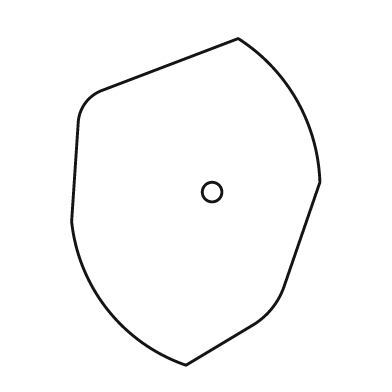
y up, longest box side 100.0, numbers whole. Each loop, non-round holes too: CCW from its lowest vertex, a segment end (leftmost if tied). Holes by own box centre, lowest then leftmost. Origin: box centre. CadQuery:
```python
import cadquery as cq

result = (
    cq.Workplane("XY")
    .moveTo(-3.0, -50.0)
    .lineTo(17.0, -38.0)
    .threePointArc((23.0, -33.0), (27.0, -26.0))
    .lineTo(38.0, 6.0)
    .threePointArc((31.0, 31.0), (13.0, 50.0))
    .lineTo(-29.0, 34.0)
    .threePointArc((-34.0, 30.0), (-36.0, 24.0))
    .lineTo(-38.0, -6.0)
    .threePointArc((-27.0, -33.0), (-3.0, -50.0))
    .close()
    .moveTo(5.0, 3.0)
    .circle(3.0)
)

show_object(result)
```